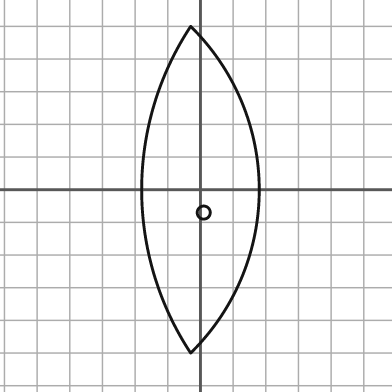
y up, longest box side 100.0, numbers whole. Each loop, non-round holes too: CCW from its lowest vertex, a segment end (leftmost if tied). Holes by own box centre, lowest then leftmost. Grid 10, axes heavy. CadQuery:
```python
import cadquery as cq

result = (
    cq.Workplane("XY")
    .moveTo(-3.0, -50.0)
    .threePointArc((18.0, 0.0), (-3.0, 50.0))
    .threePointArc((-18.0, 0.0), (-3.0, -50.0))
    .close()
    .moveTo(1.0, -7.0)
    .circle(2.0)
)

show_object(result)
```